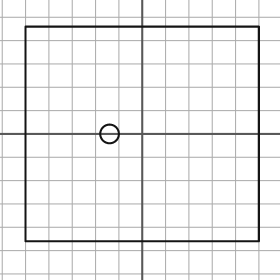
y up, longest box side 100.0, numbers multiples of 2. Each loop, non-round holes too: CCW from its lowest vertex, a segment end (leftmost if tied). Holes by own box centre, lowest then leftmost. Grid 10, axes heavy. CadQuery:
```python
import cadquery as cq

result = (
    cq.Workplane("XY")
    .moveTo(-50.0, -46.0)
    .lineTo(50.0, -46.0)
    .lineTo(50.0, 46.0)
    .lineTo(-50.0, 46.0)
    .close()
    .moveTo(-14.0, 0.0)
    .circle(4.0)
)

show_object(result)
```